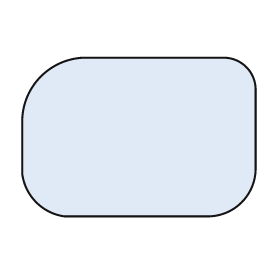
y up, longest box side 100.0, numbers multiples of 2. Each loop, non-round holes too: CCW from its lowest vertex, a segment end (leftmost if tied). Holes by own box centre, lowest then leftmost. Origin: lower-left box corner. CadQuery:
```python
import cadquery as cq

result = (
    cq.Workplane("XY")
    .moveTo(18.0, 0.0)
    .lineTo(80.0, 0.0)
    .threePointArc((94.0, 6.0), (100.0, 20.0))
    .lineTo(100.0, 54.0)
    .threePointArc((96.0, 64.0), (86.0, 68.0))
    .lineTo(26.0, 68.0)
    .threePointArc((8.0, 60.0), (0.0, 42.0))
    .lineTo(0.0, 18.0)
    .threePointArc((6.0, 6.0), (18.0, 0.0))
    .close()
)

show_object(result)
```